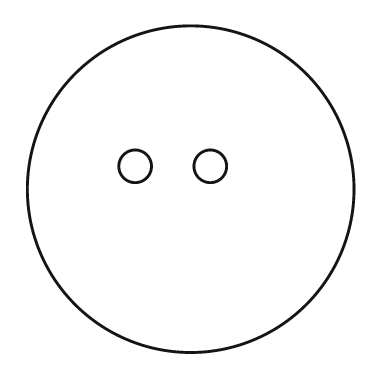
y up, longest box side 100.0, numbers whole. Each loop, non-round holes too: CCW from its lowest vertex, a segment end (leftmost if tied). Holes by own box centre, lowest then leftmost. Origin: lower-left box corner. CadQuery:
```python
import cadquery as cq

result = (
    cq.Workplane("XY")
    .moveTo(50.0, 50.0)
    .circle(50.0)
    .moveTo(33.0, 57.0)
    .circle(5.0)
    .moveTo(56.0, 57.0)
    .circle(5.0)
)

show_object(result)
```